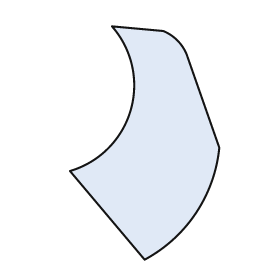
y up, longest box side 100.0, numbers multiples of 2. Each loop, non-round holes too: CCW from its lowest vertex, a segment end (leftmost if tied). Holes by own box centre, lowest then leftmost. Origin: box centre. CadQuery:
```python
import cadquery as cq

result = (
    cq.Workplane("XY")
    .moveTo(0.0, -50.0)
    .threePointArc((22.0, -30.0), (32.0, -2.0))
    .lineTo(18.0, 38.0)
    .threePointArc((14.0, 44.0), (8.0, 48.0))
    .lineTo(-14.0, 50.0)
    .threePointArc((-6.0, 14.0), (-32.0, -12.0))
    .close()
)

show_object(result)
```